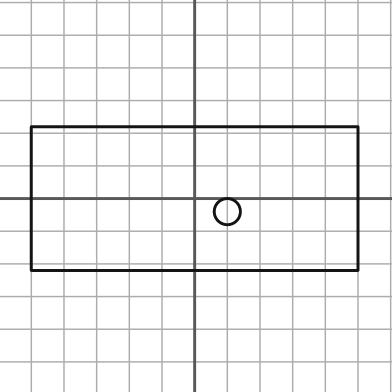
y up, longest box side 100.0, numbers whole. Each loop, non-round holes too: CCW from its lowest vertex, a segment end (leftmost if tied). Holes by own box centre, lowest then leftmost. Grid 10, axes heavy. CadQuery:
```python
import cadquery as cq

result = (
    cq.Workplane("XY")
    .moveTo(-50.0, -22.0)
    .lineTo(50.0, -22.0)
    .lineTo(50.0, 22.0)
    .lineTo(-50.0, 22.0)
    .close()
    .moveTo(10.0, -4.0)
    .circle(4.0)
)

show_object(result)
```